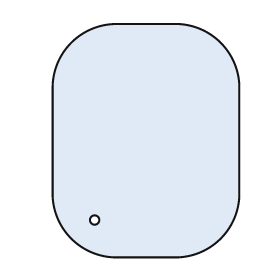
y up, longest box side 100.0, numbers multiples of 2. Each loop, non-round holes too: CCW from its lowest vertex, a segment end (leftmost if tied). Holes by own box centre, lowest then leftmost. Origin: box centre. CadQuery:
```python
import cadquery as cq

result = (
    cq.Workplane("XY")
    .moveTo(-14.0, -50.0)
    .lineTo(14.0, -50.0)
    .threePointArc((32.0, -42.0), (40.0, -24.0))
    .lineTo(40.0, 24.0)
    .threePointArc((32.0, 42.0), (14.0, 50.0))
    .lineTo(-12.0, 50.0)
    .threePointArc((-32.0, 42.0), (-40.0, 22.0))
    .lineTo(-40.0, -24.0)
    .threePointArc((-32.0, -42.0), (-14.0, -50.0))
    .close()
    .moveTo(-22.0, -34.0)
    .circle(2.0)
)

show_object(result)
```